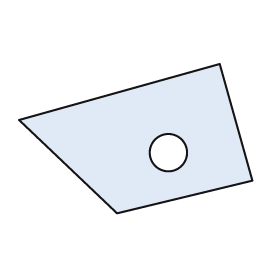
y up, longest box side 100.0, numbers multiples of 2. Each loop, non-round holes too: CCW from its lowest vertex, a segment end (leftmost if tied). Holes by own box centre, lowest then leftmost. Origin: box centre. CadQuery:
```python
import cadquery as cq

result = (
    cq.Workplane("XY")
    .moveTo(-8.0, -32.0)
    .lineTo(50.0, -18.0)
    .lineTo(36.0, 32.0)
    .lineTo(-50.0, 8.0)
    .close()
    .moveTo(14.0, -6.0)
    .circle(8.0)
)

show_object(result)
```